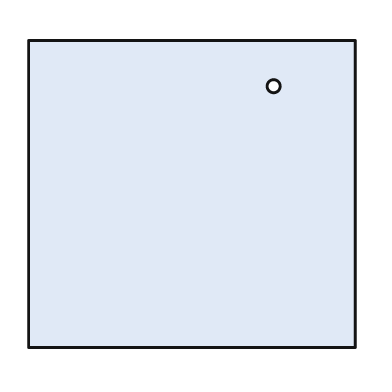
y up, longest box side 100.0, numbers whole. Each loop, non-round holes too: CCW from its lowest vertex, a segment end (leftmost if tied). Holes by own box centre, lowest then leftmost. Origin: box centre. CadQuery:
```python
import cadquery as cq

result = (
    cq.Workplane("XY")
    .moveTo(-50.0, -47.0)
    .lineTo(50.0, -47.0)
    .lineTo(50.0, 47.0)
    .lineTo(-50.0, 47.0)
    .close()
    .moveTo(25.0, 33.0)
    .circle(2.0)
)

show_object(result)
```